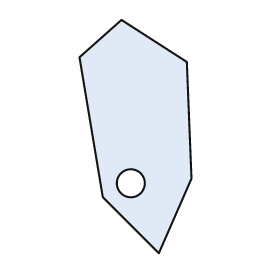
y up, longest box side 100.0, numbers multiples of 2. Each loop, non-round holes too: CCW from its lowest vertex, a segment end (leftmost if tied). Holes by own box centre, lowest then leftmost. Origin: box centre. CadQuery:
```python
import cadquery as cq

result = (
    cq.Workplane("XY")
    .moveTo(10.0, -50.0)
    .lineTo(24.0, -18.0)
    .lineTo(22.0, 32.0)
    .lineTo(-6.0, 50.0)
    .lineTo(-24.0, 34.0)
    .lineTo(-14.0, -26.0)
    .close()
    .moveTo(-2.0, -20.0)
    .circle(6.0)
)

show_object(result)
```